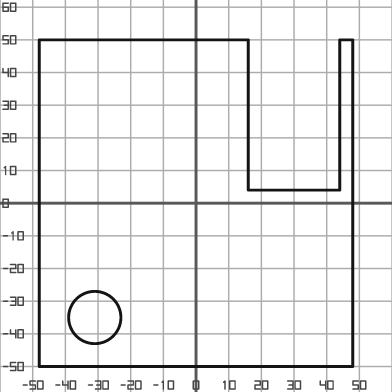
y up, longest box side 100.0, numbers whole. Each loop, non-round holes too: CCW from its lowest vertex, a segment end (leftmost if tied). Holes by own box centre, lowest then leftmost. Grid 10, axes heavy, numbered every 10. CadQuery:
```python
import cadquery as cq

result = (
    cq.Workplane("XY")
    .moveTo(-48.0, -50.0)
    .lineTo(48.0, -50.0)
    .lineTo(48.0, 50.0)
    .lineTo(44.0, 50.0)
    .lineTo(44.0, 4.0)
    .lineTo(16.0, 4.0)
    .lineTo(16.0, 50.0)
    .lineTo(-48.0, 50.0)
    .close()
    .moveTo(-31.0, -35.0)
    .circle(8.0)
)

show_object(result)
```